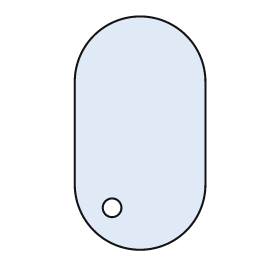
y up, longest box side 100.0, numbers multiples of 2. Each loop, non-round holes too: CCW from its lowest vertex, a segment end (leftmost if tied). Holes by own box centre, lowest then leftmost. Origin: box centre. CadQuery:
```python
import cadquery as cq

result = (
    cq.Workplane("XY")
    .moveTo(-28.0, -22.0)
    .threePointArc((0.0, -50.0), (28.0, -22.0))
    .lineTo(28.0, 22.0)
    .threePointArc((0.0, 50.0), (-28.0, 22.0))
    .close()
    .moveTo(-12.0, -32.0)
    .circle(4.0)
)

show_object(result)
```